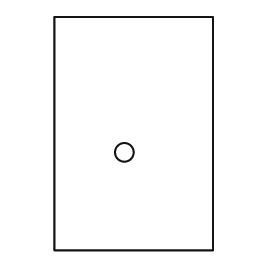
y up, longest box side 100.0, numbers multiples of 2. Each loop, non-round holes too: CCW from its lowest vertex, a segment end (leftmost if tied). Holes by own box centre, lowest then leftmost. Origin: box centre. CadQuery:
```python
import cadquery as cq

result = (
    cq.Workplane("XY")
    .moveTo(-34.0, -50.0)
    .lineTo(34.0, -50.0)
    .lineTo(34.0, 50.0)
    .lineTo(-34.0, 50.0)
    .close()
    .moveTo(-4.0, -8.0)
    .circle(4.0)
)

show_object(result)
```